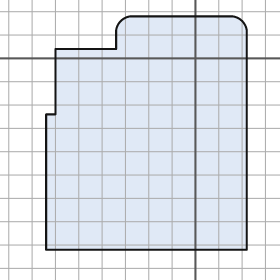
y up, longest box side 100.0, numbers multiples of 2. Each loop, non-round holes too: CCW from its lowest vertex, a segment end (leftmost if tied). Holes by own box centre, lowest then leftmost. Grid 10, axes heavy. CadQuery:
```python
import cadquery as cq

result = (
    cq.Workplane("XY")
    .moveTo(-64.0, -82.0)
    .lineTo(22.0, -82.0)
    .lineTo(22.0, 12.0)
    .threePointArc((20.0, 16.0), (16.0, 18.0))
    .lineTo(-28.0, 18.0)
    .threePointArc((-32.0, 16.0), (-34.0, 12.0))
    .lineTo(-34.0, 4.0)
    .lineTo(-60.0, 4.0)
    .lineTo(-60.0, -24.0)
    .lineTo(-64.0, -24.0)
    .close()
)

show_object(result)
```